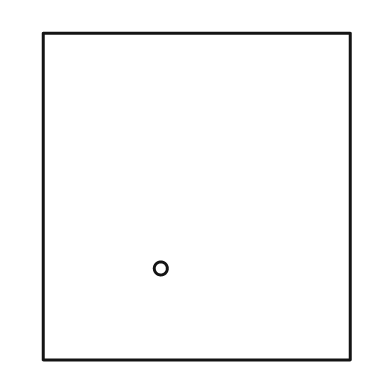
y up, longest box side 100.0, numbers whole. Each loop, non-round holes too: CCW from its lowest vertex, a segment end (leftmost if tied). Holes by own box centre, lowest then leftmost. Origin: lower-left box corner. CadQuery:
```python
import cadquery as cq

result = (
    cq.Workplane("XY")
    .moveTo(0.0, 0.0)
    .lineTo(94.0, 0.0)
    .lineTo(94.0, 100.0)
    .lineTo(0.0, 100.0)
    .close()
    .moveTo(36.0, 28.0)
    .circle(2.0)
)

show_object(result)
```